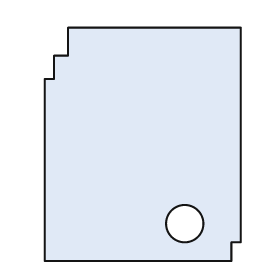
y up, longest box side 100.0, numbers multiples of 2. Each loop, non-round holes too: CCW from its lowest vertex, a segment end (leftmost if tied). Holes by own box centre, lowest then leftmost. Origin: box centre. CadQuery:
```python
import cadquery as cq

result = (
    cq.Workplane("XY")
    .moveTo(-42.0, -50.0)
    .lineTo(38.0, -50.0)
    .lineTo(38.0, -42.0)
    .lineTo(42.0, -42.0)
    .lineTo(42.0, 50.0)
    .lineTo(-32.0, 50.0)
    .lineTo(-32.0, 38.0)
    .lineTo(-38.0, 38.0)
    .lineTo(-38.0, 28.0)
    .lineTo(-42.0, 28.0)
    .close()
    .moveTo(18.0, -34.0)
    .circle(8.0)
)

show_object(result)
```